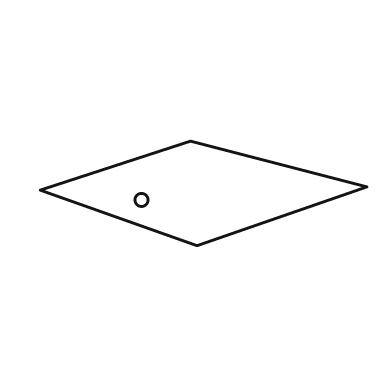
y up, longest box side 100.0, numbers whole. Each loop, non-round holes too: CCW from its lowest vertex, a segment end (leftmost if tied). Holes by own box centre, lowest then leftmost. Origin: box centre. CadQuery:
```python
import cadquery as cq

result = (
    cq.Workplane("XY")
    .moveTo(-2.0, -16.0)
    .lineTo(50.0, 2.0)
    .lineTo(-4.0, 16.0)
    .lineTo(-50.0, 1.0)
    .close()
    .moveTo(-19.0, -2.0)
    .circle(2.0)
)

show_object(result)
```